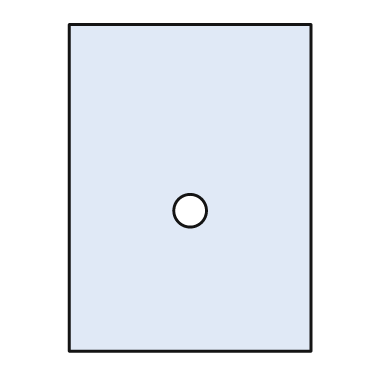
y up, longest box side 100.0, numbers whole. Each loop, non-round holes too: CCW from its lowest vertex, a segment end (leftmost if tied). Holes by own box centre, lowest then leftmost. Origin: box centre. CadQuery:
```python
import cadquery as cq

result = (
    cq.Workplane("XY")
    .moveTo(-37.0, -50.0)
    .lineTo(37.0, -50.0)
    .lineTo(37.0, 50.0)
    .lineTo(-37.0, 50.0)
    .close()
    .moveTo(0.0, -7.0)
    .circle(5.0)
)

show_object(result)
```